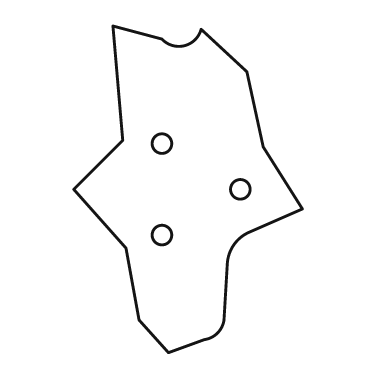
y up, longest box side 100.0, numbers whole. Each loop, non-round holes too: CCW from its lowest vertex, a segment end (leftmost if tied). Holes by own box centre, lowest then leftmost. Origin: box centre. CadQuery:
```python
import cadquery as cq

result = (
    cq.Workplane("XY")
    .moveTo(-6.0, -50.0)
    .lineTo(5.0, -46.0)
    .threePointArc((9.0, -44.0), (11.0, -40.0))
    .lineTo(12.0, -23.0)
    .threePointArc((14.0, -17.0), (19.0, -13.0))
    .lineTo(35.0, -6.0)
    .lineTo(23.0, 13.0)
    .lineTo(18.0, 36.0)
    .lineTo(4.0, 49.0)
    .threePointArc((-1.0, 44.0), (-8.0, 46.0))
    .lineTo(-23.0, 50.0)
    .lineTo(-20.0, 15.0)
    .lineTo(-35.0, 0.0)
    .lineTo(-19.0, -18.0)
    .lineTo(-15.0, -40.0)
    .close()
    .moveTo(-8.0, -14.0)
    .circle(3.0)
    .moveTo(16.0, 0.0)
    .circle(3.0)
    .moveTo(-8.0, 14.0)
    .circle(3.0)
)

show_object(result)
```